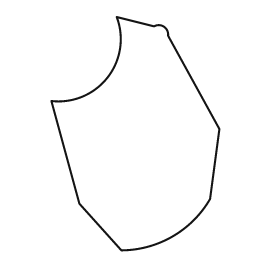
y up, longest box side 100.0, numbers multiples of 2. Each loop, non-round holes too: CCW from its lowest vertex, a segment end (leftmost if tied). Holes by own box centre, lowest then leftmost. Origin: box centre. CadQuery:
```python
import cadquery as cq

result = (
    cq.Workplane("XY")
    .moveTo(-6.0, -50.0)
    .threePointArc((16.0, -44.0), (32.0, -28.0))
    .lineTo(36.0, 2.0)
    .lineTo(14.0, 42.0)
    .threePointArc((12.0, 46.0), (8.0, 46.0))
    .lineTo(-8.0, 50.0)
    .threePointArc((-12.0, 24.0), (-36.0, 14.0))
    .lineTo(-24.0, -30.0)
    .close()
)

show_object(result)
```